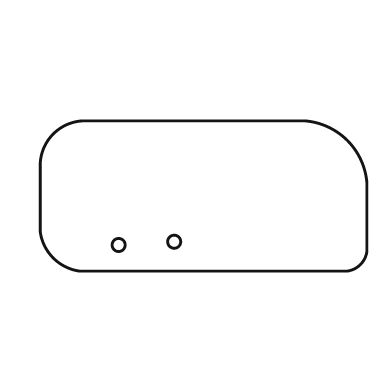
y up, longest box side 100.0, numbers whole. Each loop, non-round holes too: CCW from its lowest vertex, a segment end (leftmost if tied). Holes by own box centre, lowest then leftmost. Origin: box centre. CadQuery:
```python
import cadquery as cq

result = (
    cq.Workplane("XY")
    .moveTo(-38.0, -23.0)
    .lineTo(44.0, -23.0)
    .threePointArc((48.0, -21.0), (50.0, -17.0))
    .lineTo(50.0, 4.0)
    .threePointArc((44.0, 17.0), (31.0, 23.0))
    .lineTo(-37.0, 23.0)
    .threePointArc((-46.0, 19.0), (-50.0, 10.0))
    .lineTo(-50.0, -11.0)
    .threePointArc((-46.0, -19.0), (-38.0, -23.0))
    .close()
    .moveTo(-26.0, -15.0)
    .circle(2.0)
    .moveTo(-9.0, -14.0)
    .circle(2.0)
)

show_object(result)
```